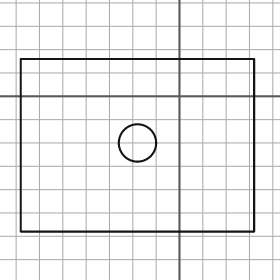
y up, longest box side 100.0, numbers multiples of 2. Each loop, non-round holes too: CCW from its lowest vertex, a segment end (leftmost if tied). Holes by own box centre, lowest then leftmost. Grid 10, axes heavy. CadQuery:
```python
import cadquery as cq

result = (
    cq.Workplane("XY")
    .moveTo(-68.0, -58.0)
    .lineTo(32.0, -58.0)
    .lineTo(32.0, 16.0)
    .lineTo(-68.0, 16.0)
    .close()
    .moveTo(-18.0, -20.0)
    .circle(8.0)
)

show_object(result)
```